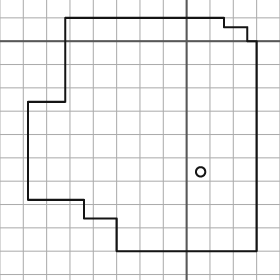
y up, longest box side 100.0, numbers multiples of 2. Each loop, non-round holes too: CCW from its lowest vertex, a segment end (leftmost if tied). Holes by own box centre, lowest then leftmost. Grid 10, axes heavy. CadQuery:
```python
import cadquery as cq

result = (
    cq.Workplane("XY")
    .moveTo(-30.0, -90.0)
    .lineTo(30.0, -90.0)
    .lineTo(30.0, 0.0)
    .lineTo(26.0, 0.0)
    .lineTo(26.0, 6.0)
    .lineTo(16.0, 6.0)
    .lineTo(16.0, 10.0)
    .lineTo(-52.0, 10.0)
    .lineTo(-52.0, -26.0)
    .lineTo(-68.0, -26.0)
    .lineTo(-68.0, -68.0)
    .lineTo(-44.0, -68.0)
    .lineTo(-44.0, -76.0)
    .lineTo(-30.0, -76.0)
    .close()
    .moveTo(6.0, -56.0)
    .circle(2.0)
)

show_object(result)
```